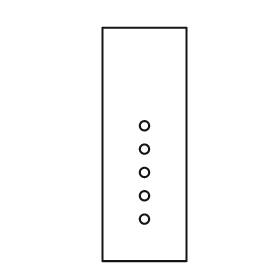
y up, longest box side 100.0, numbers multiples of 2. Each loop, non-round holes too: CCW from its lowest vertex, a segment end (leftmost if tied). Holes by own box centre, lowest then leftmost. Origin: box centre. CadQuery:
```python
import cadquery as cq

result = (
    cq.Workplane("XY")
    .moveTo(-18.0, -50.0)
    .lineTo(18.0, -50.0)
    .lineTo(18.0, 50.0)
    .lineTo(-18.0, 50.0)
    .close()
    .moveTo(0.0, -32.0)
    .circle(2.0)
    .moveTo(0.0, -22.0)
    .circle(2.0)
    .moveTo(0.0, -12.0)
    .circle(2.0)
    .moveTo(0.0, -2.0)
    .circle(2.0)
    .moveTo(0.0, 8.0)
    .circle(2.0)
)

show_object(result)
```